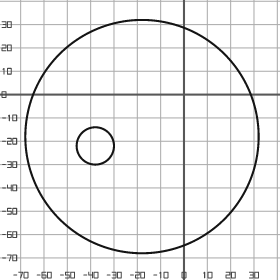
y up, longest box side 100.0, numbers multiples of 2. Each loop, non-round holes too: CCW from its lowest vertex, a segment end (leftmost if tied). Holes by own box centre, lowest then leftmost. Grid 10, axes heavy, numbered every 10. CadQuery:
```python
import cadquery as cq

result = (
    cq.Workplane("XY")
    .moveTo(-18.0, -18.0)
    .circle(50.0)
    .moveTo(-38.0, -22.0)
    .circle(8.0)
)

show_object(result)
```